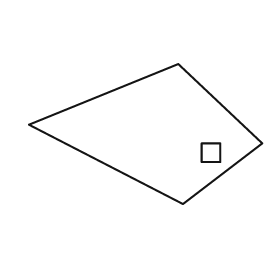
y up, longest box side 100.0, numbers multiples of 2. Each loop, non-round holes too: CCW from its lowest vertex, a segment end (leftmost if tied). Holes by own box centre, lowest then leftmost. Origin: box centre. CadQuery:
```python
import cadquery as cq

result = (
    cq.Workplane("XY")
    .moveTo(16.0, -30.0)
    .lineTo(50.0, -4.0)
    .lineTo(14.0, 30.0)
    .lineTo(-50.0, 4.0)
    .close()
    .moveTo(24.0, -12.0)
    .lineTo(32.0, -12.0)
    .lineTo(32.0, -4.0)
    .lineTo(24.0, -4.0)
    .close()
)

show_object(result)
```